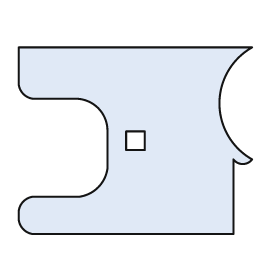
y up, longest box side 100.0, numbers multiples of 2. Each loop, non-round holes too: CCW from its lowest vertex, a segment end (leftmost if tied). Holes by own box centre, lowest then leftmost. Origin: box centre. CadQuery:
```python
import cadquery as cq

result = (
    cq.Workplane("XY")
    .moveTo(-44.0, -40.0)
    .lineTo(42.0, -40.0)
    .lineTo(42.0, -8.0)
    .threePointArc((46.0, -10.0), (50.0, -8.0))
    .threePointArc((36.0, 16.0), (50.0, 40.0))
    .lineTo(-50.0, 40.0)
    .lineTo(-50.0, 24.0)
    .threePointArc((-48.0, 20.0), (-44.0, 18.0))
    .lineTo(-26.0, 18.0)
    .threePointArc((-16.0, 14.0), (-12.0, 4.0))
    .lineTo(-12.0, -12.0)
    .threePointArc((-16.0, -20.0), (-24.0, -24.0))
    .lineTo(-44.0, -24.0)
    .threePointArc((-48.0, -26.0), (-50.0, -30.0))
    .lineTo(-50.0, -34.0)
    .threePointArc((-48.0, -38.0), (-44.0, -40.0))
    .close()
    .moveTo(-4.0, -4.0)
    .lineTo(4.0, -4.0)
    .lineTo(4.0, 4.0)
    .lineTo(-4.0, 4.0)
    .close()
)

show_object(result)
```